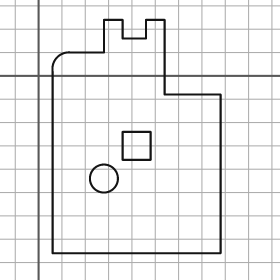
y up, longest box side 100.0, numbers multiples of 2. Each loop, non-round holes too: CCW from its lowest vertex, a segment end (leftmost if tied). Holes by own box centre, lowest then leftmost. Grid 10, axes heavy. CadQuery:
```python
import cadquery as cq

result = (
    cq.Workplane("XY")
    .moveTo(6.0, -76.0)
    .lineTo(78.0, -76.0)
    .lineTo(78.0, -8.0)
    .lineTo(54.0, -8.0)
    .lineTo(54.0, 24.0)
    .lineTo(46.0, 24.0)
    .lineTo(46.0, 16.0)
    .lineTo(36.0, 16.0)
    .lineTo(36.0, 24.0)
    .lineTo(28.0, 24.0)
    .lineTo(28.0, 10.0)
    .lineTo(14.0, 10.0)
    .threePointArc((8.0, 8.0), (6.0, 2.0))
    .close()
    .moveTo(28.0, -44.0)
    .circle(6.0)
    .moveTo(36.0, -36.0)
    .lineTo(48.0, -36.0)
    .lineTo(48.0, -24.0)
    .lineTo(36.0, -24.0)
    .close()
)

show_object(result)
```